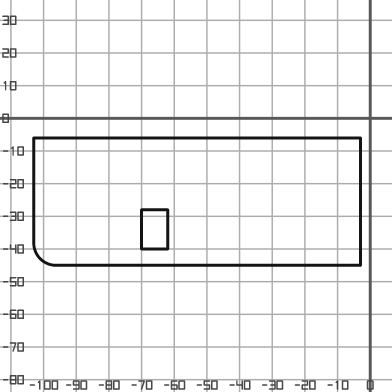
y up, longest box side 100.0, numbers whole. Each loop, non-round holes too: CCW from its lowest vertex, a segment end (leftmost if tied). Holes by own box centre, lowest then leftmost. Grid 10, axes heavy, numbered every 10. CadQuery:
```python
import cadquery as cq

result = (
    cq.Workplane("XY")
    .moveTo(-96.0, -45.0)
    .lineTo(-3.0, -45.0)
    .lineTo(-3.0, -6.0)
    .lineTo(-103.0, -6.0)
    .lineTo(-103.0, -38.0)
    .threePointArc((-101.0, -43.0), (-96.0, -45.0))
    .close()
    .moveTo(-70.0, -40.0)
    .lineTo(-62.0, -40.0)
    .lineTo(-62.0, -28.0)
    .lineTo(-70.0, -28.0)
    .close()
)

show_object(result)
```